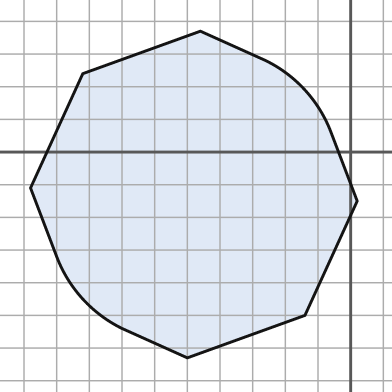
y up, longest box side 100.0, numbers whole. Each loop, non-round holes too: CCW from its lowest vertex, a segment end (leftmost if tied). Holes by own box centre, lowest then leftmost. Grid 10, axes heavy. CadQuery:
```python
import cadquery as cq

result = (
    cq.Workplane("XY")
    .moveTo(-50.0, -63.0)
    .lineTo(-14.0, -50.0)
    .lineTo(2.0, -15.0)
    .lineTo(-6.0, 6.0)
    .threePointArc((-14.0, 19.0), (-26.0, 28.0))
    .lineTo(-46.0, 37.0)
    .lineTo(-82.0, 24.0)
    .lineTo(-98.0, -11.0)
    .lineTo(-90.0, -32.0)
    .threePointArc((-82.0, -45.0), (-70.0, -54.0))
    .close()
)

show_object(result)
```